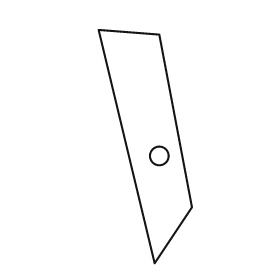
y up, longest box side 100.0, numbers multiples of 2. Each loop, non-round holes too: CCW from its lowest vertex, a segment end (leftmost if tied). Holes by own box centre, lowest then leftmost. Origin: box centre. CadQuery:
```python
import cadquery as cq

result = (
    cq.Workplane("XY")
    .moveTo(4.0, -50.0)
    .lineTo(20.0, -26.0)
    .lineTo(6.0, 48.0)
    .lineTo(-20.0, 50.0)
    .close()
    .moveTo(6.0, -4.0)
    .circle(4.0)
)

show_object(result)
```